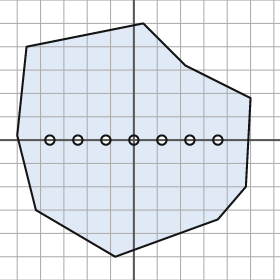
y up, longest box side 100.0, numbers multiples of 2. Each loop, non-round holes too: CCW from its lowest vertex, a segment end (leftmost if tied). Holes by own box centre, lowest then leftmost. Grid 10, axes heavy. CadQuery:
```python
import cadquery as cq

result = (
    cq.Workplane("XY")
    .moveTo(-8.0, -50.0)
    .lineTo(36.0, -34.0)
    .lineTo(48.0, -20.0)
    .lineTo(50.0, 18.0)
    .lineTo(22.0, 32.0)
    .lineTo(4.0, 50.0)
    .lineTo(-46.0, 40.0)
    .lineTo(-50.0, 2.0)
    .lineTo(-42.0, -30.0)
    .close()
    .moveTo(-36.0, 0.0)
    .circle(2.0)
    .moveTo(-24.0, 0.0)
    .circle(2.0)
    .moveTo(-12.0, 0.0)
    .circle(2.0)
    .moveTo(0.0, 0.0)
    .circle(2.0)
    .moveTo(12.0, 0.0)
    .circle(2.0)
    .moveTo(24.0, 0.0)
    .circle(2.0)
    .moveTo(36.0, 0.0)
    .circle(2.0)
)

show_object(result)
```